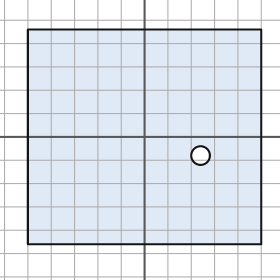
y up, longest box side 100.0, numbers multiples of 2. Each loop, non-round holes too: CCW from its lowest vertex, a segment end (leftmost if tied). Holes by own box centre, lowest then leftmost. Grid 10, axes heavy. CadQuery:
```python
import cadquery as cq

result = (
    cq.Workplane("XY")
    .moveTo(-50.0, -46.0)
    .lineTo(50.0, -46.0)
    .lineTo(50.0, 46.0)
    .lineTo(-50.0, 46.0)
    .close()
    .moveTo(24.0, -8.0)
    .circle(4.0)
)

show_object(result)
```